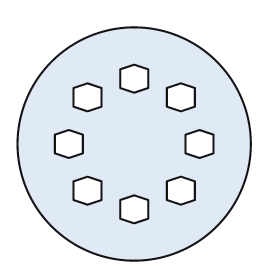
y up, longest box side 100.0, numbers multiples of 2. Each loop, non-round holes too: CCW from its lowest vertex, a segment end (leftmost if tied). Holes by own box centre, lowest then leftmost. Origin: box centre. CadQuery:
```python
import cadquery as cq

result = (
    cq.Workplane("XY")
    .moveTo(0.0, 0.0)
    .circle(50.0)
    .moveTo(0.0, -34.0)
    .lineTo(6.0, -32.0)
    .lineTo(6.0, -24.0)
    .lineTo(0.0, -22.0)
    .lineTo(-6.0, -24.0)
    .lineTo(-6.0, -32.0)
    .close()
    .moveTo(-20.0, -26.0)
    .lineTo(-14.0, -24.0)
    .lineTo(-14.0, -16.0)
    .lineTo(-20.0, -14.0)
    .lineTo(-26.0, -16.0)
    .lineTo(-26.0, -24.0)
    .close()
    .moveTo(20.0, -26.0)
    .lineTo(26.0, -24.0)
    .lineTo(26.0, -16.0)
    .lineTo(20.0, -14.0)
    .lineTo(14.0, -16.0)
    .lineTo(14.0, -24.0)
    .close()
    .moveTo(-28.0, -6.0)
    .lineTo(-22.0, -4.0)
    .lineTo(-22.0, 4.0)
    .lineTo(-28.0, 6.0)
    .lineTo(-34.0, 4.0)
    .lineTo(-34.0, -4.0)
    .close()
    .moveTo(28.0, -6.0)
    .lineTo(34.0, -4.0)
    .lineTo(34.0, 4.0)
    .lineTo(28.0, 6.0)
    .lineTo(22.0, 4.0)
    .lineTo(22.0, -4.0)
    .close()
    .moveTo(-20.0, 14.0)
    .lineTo(-14.0, 16.0)
    .lineTo(-14.0, 24.0)
    .lineTo(-20.0, 26.0)
    .lineTo(-26.0, 24.0)
    .lineTo(-26.0, 16.0)
    .close()
    .moveTo(20.0, 14.0)
    .lineTo(26.0, 16.0)
    .lineTo(26.0, 24.0)
    .lineTo(20.0, 26.0)
    .lineTo(14.0, 24.0)
    .lineTo(14.0, 16.0)
    .close()
    .moveTo(0.0, 22.0)
    .lineTo(6.0, 24.0)
    .lineTo(6.0, 32.0)
    .lineTo(0.0, 34.0)
    .lineTo(-6.0, 32.0)
    .lineTo(-6.0, 24.0)
    .close()
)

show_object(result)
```